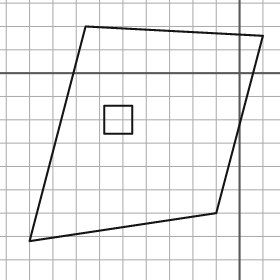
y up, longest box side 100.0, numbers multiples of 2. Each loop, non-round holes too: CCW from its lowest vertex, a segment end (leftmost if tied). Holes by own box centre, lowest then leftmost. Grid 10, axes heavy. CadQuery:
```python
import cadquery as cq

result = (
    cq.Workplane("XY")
    .moveTo(-90.0, -72.0)
    .lineTo(-10.0, -60.0)
    .lineTo(10.0, 16.0)
    .lineTo(-66.0, 20.0)
    .close()
    .moveTo(-58.0, -26.0)
    .lineTo(-46.0, -26.0)
    .lineTo(-46.0, -14.0)
    .lineTo(-58.0, -14.0)
    .close()
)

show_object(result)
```